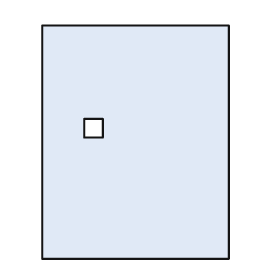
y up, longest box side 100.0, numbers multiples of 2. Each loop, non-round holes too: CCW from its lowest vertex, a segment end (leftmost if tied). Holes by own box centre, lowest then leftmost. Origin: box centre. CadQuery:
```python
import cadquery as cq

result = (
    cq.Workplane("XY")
    .moveTo(-40.0, -50.0)
    .lineTo(40.0, -50.0)
    .lineTo(40.0, 50.0)
    .lineTo(-40.0, 50.0)
    .close()
    .moveTo(-22.0, 2.0)
    .lineTo(-14.0, 2.0)
    .lineTo(-14.0, 10.0)
    .lineTo(-22.0, 10.0)
    .close()
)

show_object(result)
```